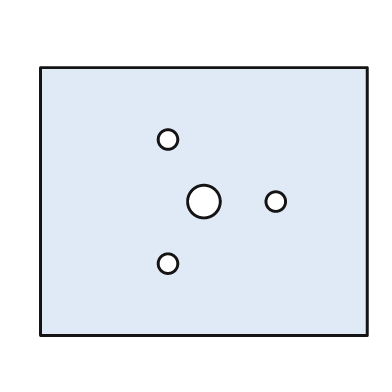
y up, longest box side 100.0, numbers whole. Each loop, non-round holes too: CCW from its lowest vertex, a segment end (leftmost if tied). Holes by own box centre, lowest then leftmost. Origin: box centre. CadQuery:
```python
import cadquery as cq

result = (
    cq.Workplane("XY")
    .moveTo(-50.0, -41.0)
    .lineTo(50.0, -41.0)
    .lineTo(50.0, 41.0)
    .lineTo(-50.0, 41.0)
    .close()
    .moveTo(-11.0, -19.0)
    .circle(3.0)
    .moveTo(0.0, 0.0)
    .circle(5.0)
    .moveTo(22.0, 0.0)
    .circle(3.0)
    .moveTo(-11.0, 19.0)
    .circle(3.0)
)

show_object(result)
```